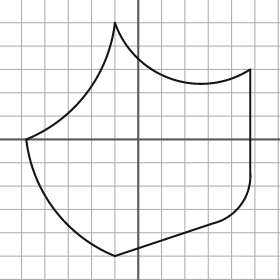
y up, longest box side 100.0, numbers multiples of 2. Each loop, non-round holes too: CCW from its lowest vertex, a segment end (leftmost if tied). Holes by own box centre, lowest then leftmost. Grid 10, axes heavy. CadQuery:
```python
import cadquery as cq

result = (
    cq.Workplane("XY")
    .moveTo(-10.0, -50.0)
    .lineTo(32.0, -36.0)
    .threePointArc((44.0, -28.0), (48.0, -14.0))
    .lineTo(48.0, 30.0)
    .threePointArc((14.0, 26.0), (-10.0, 50.0))
    .threePointArc((-22.0, 20.0), (-48.0, 0.0))
    .threePointArc((-36.0, -30.0), (-10.0, -50.0))
    .close()
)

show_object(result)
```